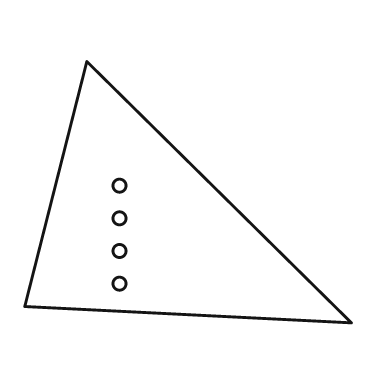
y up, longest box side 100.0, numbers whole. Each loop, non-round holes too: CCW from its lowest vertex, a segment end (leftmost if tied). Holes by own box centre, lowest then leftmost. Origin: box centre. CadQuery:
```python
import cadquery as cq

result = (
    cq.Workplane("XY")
    .moveTo(50.0, -40.0)
    .lineTo(-31.0, 40.0)
    .lineTo(-50.0, -35.0)
    .close()
    .moveTo(-21.0, -28.0)
    .circle(2.0)
    .moveTo(-21.0, -18.0)
    .circle(2.0)
    .moveTo(-21.0, -8.0)
    .circle(2.0)
    .moveTo(-21.0, 2.0)
    .circle(2.0)
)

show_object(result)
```